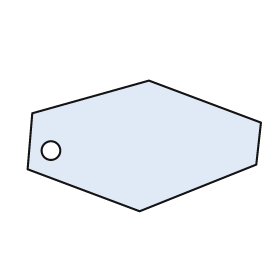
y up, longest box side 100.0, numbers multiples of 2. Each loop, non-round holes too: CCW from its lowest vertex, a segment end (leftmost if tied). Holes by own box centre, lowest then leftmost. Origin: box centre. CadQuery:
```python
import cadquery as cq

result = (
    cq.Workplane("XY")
    .moveTo(-2.0, -28.0)
    .lineTo(48.0, -8.0)
    .lineTo(50.0, 10.0)
    .lineTo(2.0, 28.0)
    .lineTo(-48.0, 14.0)
    .lineTo(-50.0, -10.0)
    .close()
    .moveTo(-40.0, -2.0)
    .circle(4.0)
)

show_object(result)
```